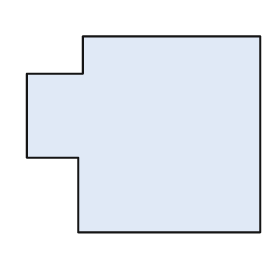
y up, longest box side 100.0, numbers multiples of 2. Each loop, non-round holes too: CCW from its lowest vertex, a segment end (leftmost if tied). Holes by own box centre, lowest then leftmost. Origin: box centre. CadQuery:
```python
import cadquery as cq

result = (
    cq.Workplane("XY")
    .moveTo(-28.0, -42.0)
    .lineTo(50.0, -42.0)
    .lineTo(50.0, 42.0)
    .lineTo(-26.0, 42.0)
    .lineTo(-26.0, 26.0)
    .lineTo(-50.0, 26.0)
    .lineTo(-50.0, -10.0)
    .lineTo(-28.0, -10.0)
    .close()
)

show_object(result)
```